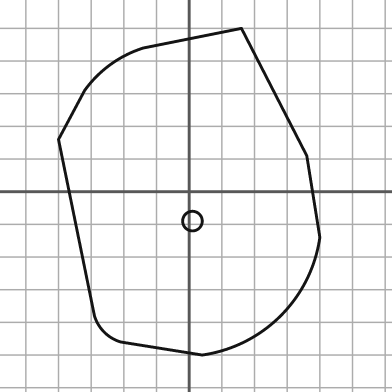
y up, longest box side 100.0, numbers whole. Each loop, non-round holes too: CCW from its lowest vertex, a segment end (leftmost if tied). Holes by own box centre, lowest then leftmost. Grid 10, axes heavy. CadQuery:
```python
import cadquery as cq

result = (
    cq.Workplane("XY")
    .moveTo(4.0, -50.0)
    .threePointArc((28.0, -38.0), (40.0, -14.0))
    .lineTo(36.0, 11.0)
    .lineTo(16.0, 50.0)
    .lineTo(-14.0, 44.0)
    .threePointArc((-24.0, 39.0), (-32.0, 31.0))
    .lineTo(-40.0, 16.0)
    .lineTo(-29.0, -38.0)
    .threePointArc((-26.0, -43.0), (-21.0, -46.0))
    .close()
    .moveTo(1.0, -9.0)
    .circle(3.0)
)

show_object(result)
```